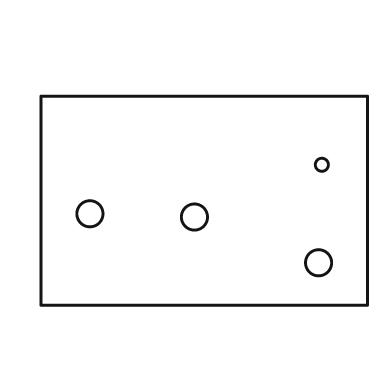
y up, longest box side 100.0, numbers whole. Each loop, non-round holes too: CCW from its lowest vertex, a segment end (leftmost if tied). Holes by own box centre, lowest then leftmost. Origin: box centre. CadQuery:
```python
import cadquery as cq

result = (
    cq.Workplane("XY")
    .moveTo(-50.0, -32.0)
    .lineTo(50.0, -32.0)
    .lineTo(50.0, 32.0)
    .lineTo(-50.0, 32.0)
    .close()
    .moveTo(35.0, -19.0)
    .circle(4.0)
    .moveTo(-3.0, -5.0)
    .circle(4.0)
    .moveTo(-35.0, -4.0)
    .circle(4.0)
    .moveTo(36.0, 11.0)
    .circle(2.0)
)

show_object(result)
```